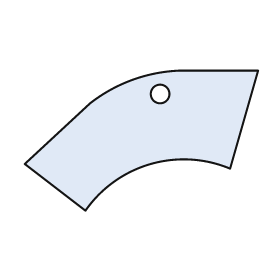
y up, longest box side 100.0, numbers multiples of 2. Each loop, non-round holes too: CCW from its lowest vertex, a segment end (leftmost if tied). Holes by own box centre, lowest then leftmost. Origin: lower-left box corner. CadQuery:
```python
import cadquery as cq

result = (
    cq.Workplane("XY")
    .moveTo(26.0, 0.0)
    .threePointArc((54.0, 20.0), (88.0, 18.0))
    .lineTo(100.0, 60.0)
    .lineTo(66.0, 60.0)
    .threePointArc((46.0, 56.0), (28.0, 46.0))
    .lineTo(0.0, 20.0)
    .close()
    .moveTo(58.0, 50.0)
    .circle(4.0)
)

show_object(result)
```